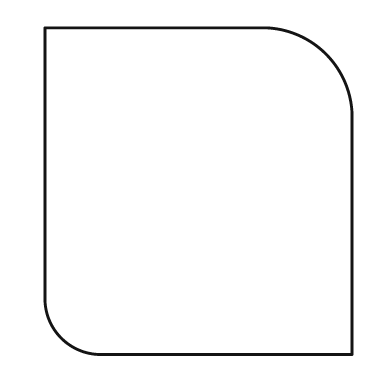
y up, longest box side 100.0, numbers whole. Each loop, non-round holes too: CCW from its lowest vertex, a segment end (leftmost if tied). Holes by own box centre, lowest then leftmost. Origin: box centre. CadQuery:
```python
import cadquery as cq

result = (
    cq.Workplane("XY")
    .moveTo(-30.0, -50.0)
    .lineTo(47.0, -50.0)
    .lineTo(47.0, 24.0)
    .threePointArc((39.0, 42.0), (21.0, 50.0))
    .lineTo(-47.0, 50.0)
    .lineTo(-47.0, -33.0)
    .threePointArc((-42.0, -45.0), (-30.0, -50.0))
    .close()
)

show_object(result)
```